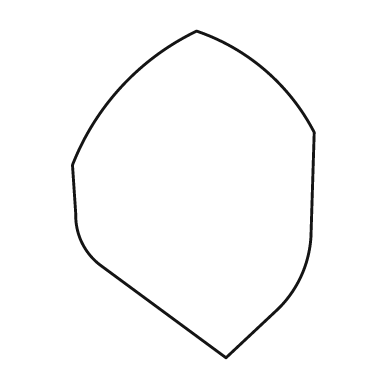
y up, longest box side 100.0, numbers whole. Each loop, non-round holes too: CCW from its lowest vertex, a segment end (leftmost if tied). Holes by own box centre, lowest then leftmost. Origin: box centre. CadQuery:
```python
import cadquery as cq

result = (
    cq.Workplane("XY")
    .moveTo(10.0, -50.0)
    .lineTo(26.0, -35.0)
    .threePointArc((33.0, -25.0), (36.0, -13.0))
    .lineTo(37.0, 19.0)
    .threePointArc((22.0, 38.0), (1.0, 50.0))
    .threePointArc((-22.0, 33.0), (-37.0, 9.0))
    .lineTo(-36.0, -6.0)
    .threePointArc((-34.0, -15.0), (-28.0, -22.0))
    .close()
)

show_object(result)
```